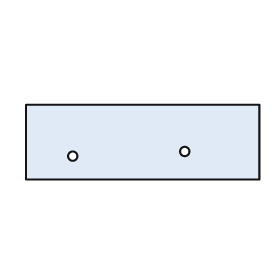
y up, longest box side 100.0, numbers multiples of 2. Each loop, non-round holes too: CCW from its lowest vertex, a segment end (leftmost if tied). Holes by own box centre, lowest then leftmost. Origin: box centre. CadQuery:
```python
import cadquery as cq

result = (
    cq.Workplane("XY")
    .moveTo(-50.0, -16.0)
    .lineTo(50.0, -16.0)
    .lineTo(50.0, 16.0)
    .lineTo(-50.0, 16.0)
    .close()
    .moveTo(-30.0, -6.0)
    .circle(2.0)
    .moveTo(18.0, -4.0)
    .circle(2.0)
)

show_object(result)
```